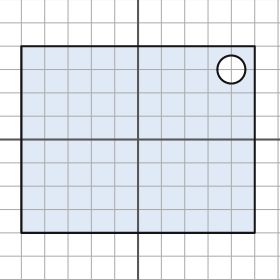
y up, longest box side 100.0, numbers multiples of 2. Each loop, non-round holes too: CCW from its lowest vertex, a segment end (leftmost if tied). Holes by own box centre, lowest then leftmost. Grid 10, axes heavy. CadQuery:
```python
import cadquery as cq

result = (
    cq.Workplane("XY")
    .moveTo(-50.0, -40.0)
    .lineTo(50.0, -40.0)
    .lineTo(50.0, 40.0)
    .lineTo(-50.0, 40.0)
    .close()
    .moveTo(40.0, 30.0)
    .circle(6.0)
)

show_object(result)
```